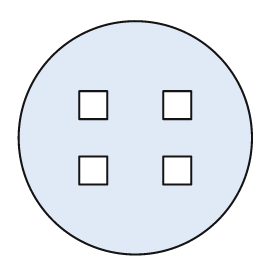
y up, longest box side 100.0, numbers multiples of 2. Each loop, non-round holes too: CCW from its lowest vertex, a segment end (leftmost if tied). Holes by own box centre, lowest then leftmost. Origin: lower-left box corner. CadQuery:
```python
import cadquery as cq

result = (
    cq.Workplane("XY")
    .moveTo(50.0, 50.0)
    .circle(50.0)
    .moveTo(26.0, 30.0)
    .lineTo(38.0, 30.0)
    .lineTo(38.0, 42.0)
    .lineTo(26.0, 42.0)
    .close()
    .moveTo(62.0, 30.0)
    .lineTo(74.0, 30.0)
    .lineTo(74.0, 42.0)
    .lineTo(62.0, 42.0)
    .close()
    .moveTo(26.0, 58.0)
    .lineTo(38.0, 58.0)
    .lineTo(38.0, 70.0)
    .lineTo(26.0, 70.0)
    .close()
    .moveTo(62.0, 58.0)
    .lineTo(74.0, 58.0)
    .lineTo(74.0, 70.0)
    .lineTo(62.0, 70.0)
    .close()
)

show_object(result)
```